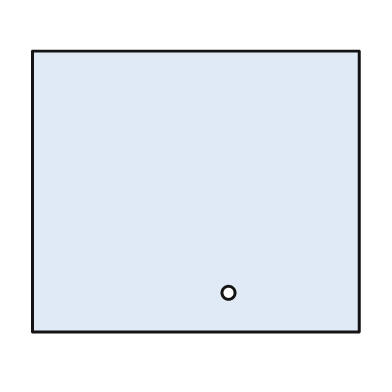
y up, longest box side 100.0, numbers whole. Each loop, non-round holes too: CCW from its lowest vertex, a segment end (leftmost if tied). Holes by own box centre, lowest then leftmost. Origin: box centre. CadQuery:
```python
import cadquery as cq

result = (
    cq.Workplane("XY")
    .moveTo(-50.0, -43.0)
    .lineTo(50.0, -43.0)
    .lineTo(50.0, 43.0)
    .lineTo(-50.0, 43.0)
    .close()
    .moveTo(10.0, -31.0)
    .circle(2.0)
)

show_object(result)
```